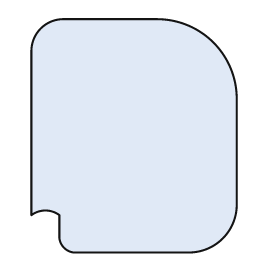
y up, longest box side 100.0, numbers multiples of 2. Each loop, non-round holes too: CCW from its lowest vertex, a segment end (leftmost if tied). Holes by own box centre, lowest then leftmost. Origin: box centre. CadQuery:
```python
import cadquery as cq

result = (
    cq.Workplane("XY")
    .moveTo(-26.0, -50.0)
    .lineTo(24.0, -50.0)
    .threePointArc((38.0, -44.0), (44.0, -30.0))
    .lineTo(44.0, 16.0)
    .threePointArc((34.0, 40.0), (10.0, 50.0))
    .lineTo(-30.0, 50.0)
    .threePointArc((-40.0, 46.0), (-44.0, 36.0))
    .lineTo(-44.0, -34.0)
    .threePointArc((-38.0, -32.0), (-32.0, -34.0))
    .lineTo(-32.0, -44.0)
    .threePointArc((-30.0, -48.0), (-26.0, -50.0))
    .close()
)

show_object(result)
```